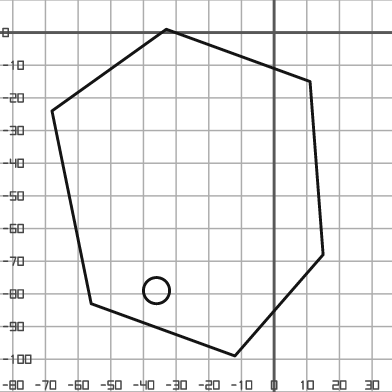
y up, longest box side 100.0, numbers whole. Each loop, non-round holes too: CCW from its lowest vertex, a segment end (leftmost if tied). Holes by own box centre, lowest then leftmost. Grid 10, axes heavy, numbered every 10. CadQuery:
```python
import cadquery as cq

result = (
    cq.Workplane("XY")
    .moveTo(-12.0, -99.0)
    .lineTo(15.0, -68.0)
    .lineTo(11.0, -15.0)
    .lineTo(-33.0, 1.0)
    .lineTo(-68.0, -24.0)
    .lineTo(-56.0, -83.0)
    .close()
    .moveTo(-36.0, -79.0)
    .circle(4.0)
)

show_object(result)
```